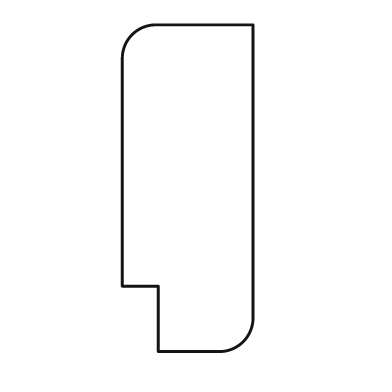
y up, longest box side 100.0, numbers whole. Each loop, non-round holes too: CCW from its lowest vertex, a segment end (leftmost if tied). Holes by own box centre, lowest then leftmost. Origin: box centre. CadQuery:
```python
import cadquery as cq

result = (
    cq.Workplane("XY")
    .moveTo(-9.0, -50.0)
    .lineTo(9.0, -50.0)
    .threePointArc((17.0, -47.0), (20.0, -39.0))
    .lineTo(20.0, 50.0)
    .lineTo(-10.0, 50.0)
    .threePointArc((-17.0, 47.0), (-20.0, 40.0))
    .lineTo(-20.0, -30.0)
    .lineTo(-9.0, -30.0)
    .close()
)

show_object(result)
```